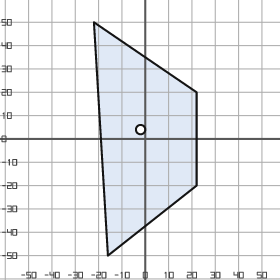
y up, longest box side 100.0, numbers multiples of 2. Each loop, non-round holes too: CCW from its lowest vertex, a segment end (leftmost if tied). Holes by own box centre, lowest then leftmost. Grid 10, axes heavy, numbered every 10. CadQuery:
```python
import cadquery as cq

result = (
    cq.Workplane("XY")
    .moveTo(-16.0, -50.0)
    .lineTo(22.0, -20.0)
    .lineTo(22.0, 20.0)
    .lineTo(-22.0, 50.0)
    .close()
    .moveTo(-2.0, 4.0)
    .circle(2.0)
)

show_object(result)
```